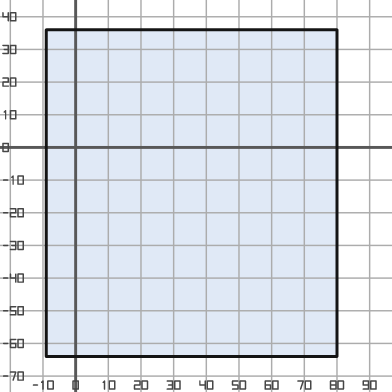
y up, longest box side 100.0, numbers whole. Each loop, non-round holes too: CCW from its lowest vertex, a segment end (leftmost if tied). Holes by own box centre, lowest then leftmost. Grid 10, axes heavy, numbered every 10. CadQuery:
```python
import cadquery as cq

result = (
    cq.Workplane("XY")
    .moveTo(-9.0, -64.0)
    .lineTo(80.0, -64.0)
    .lineTo(80.0, 36.0)
    .lineTo(-9.0, 36.0)
    .close()
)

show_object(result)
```